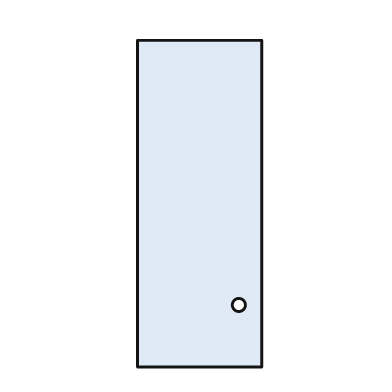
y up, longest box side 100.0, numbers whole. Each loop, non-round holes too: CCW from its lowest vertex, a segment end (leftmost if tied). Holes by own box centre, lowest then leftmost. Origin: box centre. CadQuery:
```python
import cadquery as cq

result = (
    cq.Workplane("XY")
    .moveTo(-19.0, -50.0)
    .lineTo(19.0, -50.0)
    .lineTo(19.0, 50.0)
    .lineTo(-19.0, 50.0)
    .close()
    .moveTo(12.0, -31.0)
    .circle(2.0)
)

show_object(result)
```